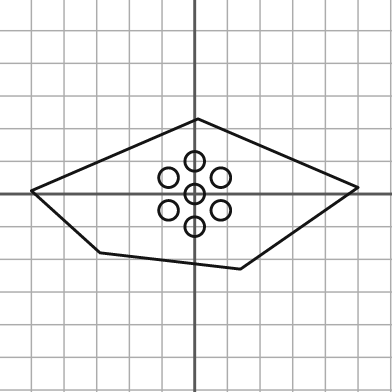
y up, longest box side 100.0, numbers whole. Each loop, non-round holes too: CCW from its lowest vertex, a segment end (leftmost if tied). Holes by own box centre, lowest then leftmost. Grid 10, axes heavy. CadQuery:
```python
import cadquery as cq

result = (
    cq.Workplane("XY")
    .moveTo(14.0, -23.0)
    .lineTo(50.0, 2.0)
    .lineTo(1.0, 23.0)
    .lineTo(-50.0, 1.0)
    .lineTo(-29.0, -18.0)
    .close()
    .moveTo(0.0, -10.0)
    .circle(3.0)
    .moveTo(-8.0, -5.0)
    .circle(3.0)
    .moveTo(8.0, -5.0)
    .circle(3.0)
    .moveTo(0.0, 0.0)
    .circle(3.0)
    .moveTo(-8.0, 5.0)
    .circle(3.0)
    .moveTo(8.0, 5.0)
    .circle(3.0)
    .moveTo(0.0, 10.0)
    .circle(3.0)
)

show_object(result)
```